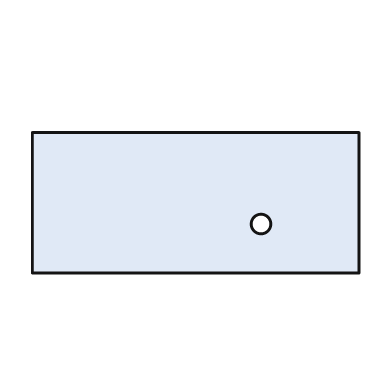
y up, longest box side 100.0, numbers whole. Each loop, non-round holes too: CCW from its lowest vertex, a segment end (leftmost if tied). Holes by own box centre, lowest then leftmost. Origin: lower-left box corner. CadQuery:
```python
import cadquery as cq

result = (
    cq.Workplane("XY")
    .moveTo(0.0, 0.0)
    .lineTo(100.0, 0.0)
    .lineTo(100.0, 43.0)
    .lineTo(0.0, 43.0)
    .close()
    .moveTo(70.0, 15.0)
    .circle(3.0)
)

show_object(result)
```